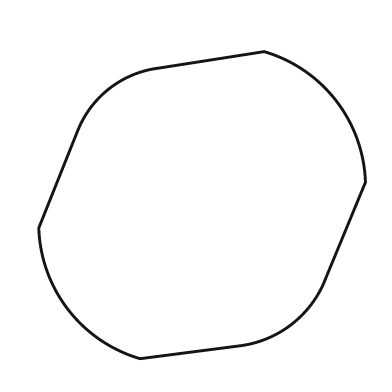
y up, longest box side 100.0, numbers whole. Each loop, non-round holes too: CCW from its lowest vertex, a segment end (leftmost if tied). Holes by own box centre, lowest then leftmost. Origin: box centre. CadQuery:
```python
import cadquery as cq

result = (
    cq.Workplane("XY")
    .moveTo(-19.0, -47.0)
    .lineTo(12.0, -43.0)
    .threePointArc((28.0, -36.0), (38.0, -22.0))
    .lineTo(50.0, 7.0)
    .threePointArc((41.0, 32.0), (19.0, 47.0))
    .lineTo(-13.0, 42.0)
    .threePointArc((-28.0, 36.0), (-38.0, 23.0))
    .lineTo(-50.0, -7.0)
    .threePointArc((-41.0, -32.0), (-19.0, -47.0))
    .close()
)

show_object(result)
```